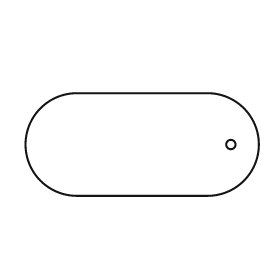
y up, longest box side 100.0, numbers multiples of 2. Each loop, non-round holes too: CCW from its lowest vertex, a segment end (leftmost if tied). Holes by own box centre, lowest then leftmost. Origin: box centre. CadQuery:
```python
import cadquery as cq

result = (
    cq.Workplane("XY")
    .moveTo(-28.0, -22.0)
    .lineTo(28.0, -22.0)
    .threePointArc((50.0, 0.0), (28.0, 22.0))
    .lineTo(-28.0, 22.0)
    .threePointArc((-50.0, 0.0), (-28.0, -22.0))
    .close()
    .moveTo(38.0, 0.0)
    .circle(2.0)
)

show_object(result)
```